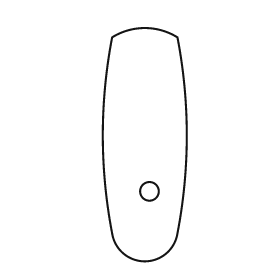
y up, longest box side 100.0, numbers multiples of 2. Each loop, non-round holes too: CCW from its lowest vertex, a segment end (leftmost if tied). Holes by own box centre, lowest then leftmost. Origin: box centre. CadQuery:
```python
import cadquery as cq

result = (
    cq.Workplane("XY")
    .moveTo(-14.0, -38.0)
    .threePointArc((0.0, -50.0), (14.0, -38.0))
    .threePointArc((18.0, 4.0), (14.0, 46.0))
    .threePointArc((0.0, 50.0), (-14.0, 46.0))
    .threePointArc((-18.0, 4.0), (-14.0, -38.0))
    .close()
    .moveTo(2.0, -20.0)
    .circle(4.0)
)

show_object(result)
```